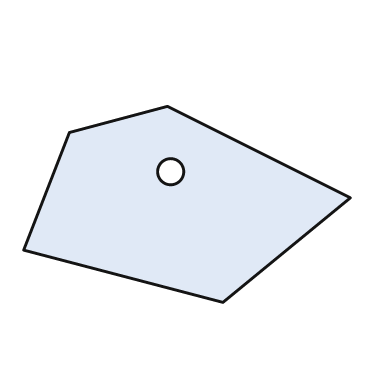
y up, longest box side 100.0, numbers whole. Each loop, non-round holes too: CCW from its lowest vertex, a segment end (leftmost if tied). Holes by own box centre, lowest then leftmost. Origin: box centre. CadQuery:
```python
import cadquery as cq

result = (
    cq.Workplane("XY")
    .moveTo(11.0, -30.0)
    .lineTo(50.0, 2.0)
    .lineTo(-6.0, 30.0)
    .lineTo(-36.0, 22.0)
    .lineTo(-50.0, -14.0)
    .close()
    .moveTo(-5.0, 10.0)
    .circle(4.0)
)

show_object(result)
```